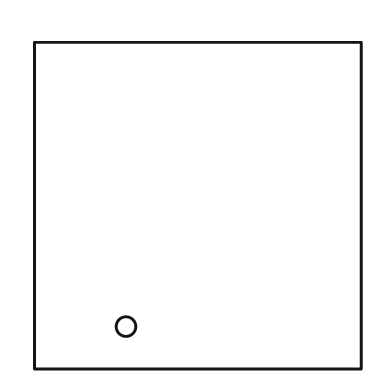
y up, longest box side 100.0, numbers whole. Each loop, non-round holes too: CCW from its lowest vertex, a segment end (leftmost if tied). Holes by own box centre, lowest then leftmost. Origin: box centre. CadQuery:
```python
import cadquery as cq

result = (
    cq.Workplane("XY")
    .moveTo(-50.0, -50.0)
    .lineTo(50.0, -50.0)
    .lineTo(50.0, 50.0)
    .lineTo(-50.0, 50.0)
    .close()
    .moveTo(-22.0, -37.0)
    .circle(3.0)
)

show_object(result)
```